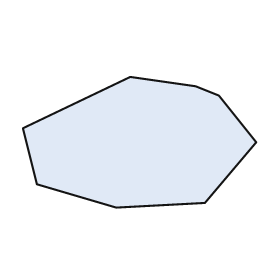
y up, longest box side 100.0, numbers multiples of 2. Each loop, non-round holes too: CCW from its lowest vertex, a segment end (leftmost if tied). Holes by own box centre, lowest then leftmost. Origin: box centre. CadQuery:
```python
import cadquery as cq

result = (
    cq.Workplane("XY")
    .moveTo(-10.0, -28.0)
    .lineTo(28.0, -26.0)
    .lineTo(50.0, 0.0)
    .lineTo(34.0, 20.0)
    .lineTo(24.0, 24.0)
    .lineTo(-4.0, 28.0)
    .lineTo(-50.0, 6.0)
    .lineTo(-44.0, -18.0)
    .close()
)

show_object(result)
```